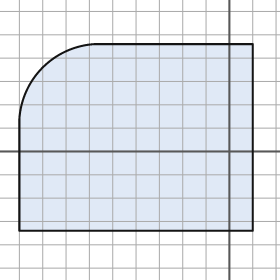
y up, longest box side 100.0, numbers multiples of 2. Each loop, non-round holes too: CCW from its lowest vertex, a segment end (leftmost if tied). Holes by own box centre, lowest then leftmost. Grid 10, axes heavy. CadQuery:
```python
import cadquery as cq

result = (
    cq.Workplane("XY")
    .moveTo(-90.0, -34.0)
    .lineTo(10.0, -34.0)
    .lineTo(10.0, 46.0)
    .lineTo(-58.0, 46.0)
    .threePointArc((-80.0, 36.0), (-90.0, 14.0))
    .close()
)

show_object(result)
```